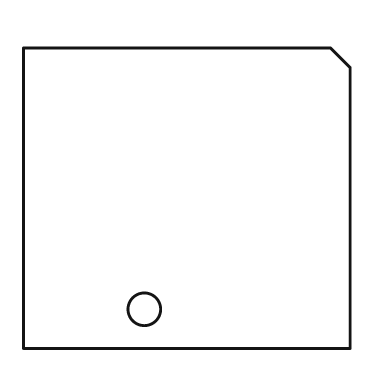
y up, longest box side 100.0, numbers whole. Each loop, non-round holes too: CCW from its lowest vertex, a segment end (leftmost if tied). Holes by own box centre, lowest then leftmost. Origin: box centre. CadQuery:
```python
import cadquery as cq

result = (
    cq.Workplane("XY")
    .moveTo(-50.0, -46.0)
    .lineTo(50.0, -46.0)
    .lineTo(50.0, 40.0)
    .lineTo(44.0, 46.0)
    .lineTo(-50.0, 46.0)
    .close()
    .moveTo(-13.0, -34.0)
    .circle(5.0)
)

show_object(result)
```